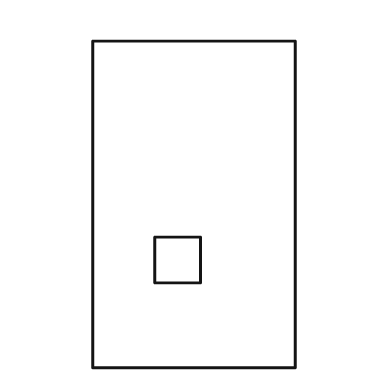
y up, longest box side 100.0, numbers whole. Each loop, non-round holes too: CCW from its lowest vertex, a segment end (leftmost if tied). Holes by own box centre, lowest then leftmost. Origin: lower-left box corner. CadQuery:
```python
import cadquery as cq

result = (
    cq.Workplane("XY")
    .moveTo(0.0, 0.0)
    .lineTo(62.0, 0.0)
    .lineTo(62.0, 100.0)
    .lineTo(0.0, 100.0)
    .close()
    .moveTo(19.0, 26.0)
    .lineTo(33.0, 26.0)
    .lineTo(33.0, 40.0)
    .lineTo(19.0, 40.0)
    .close()
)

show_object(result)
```